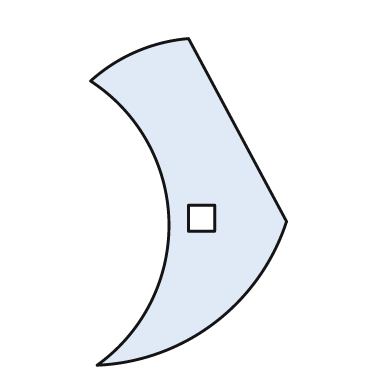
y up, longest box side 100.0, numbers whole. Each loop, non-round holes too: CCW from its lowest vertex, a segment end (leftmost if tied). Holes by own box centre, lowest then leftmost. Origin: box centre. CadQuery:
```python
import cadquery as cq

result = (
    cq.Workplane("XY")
    .moveTo(-28.0, -50.0)
    .threePointArc((8.0, -37.0), (30.0, -6.0))
    .lineTo(0.0, 50.0)
    .threePointArc((-16.0, 46.0), (-30.0, 37.0))
    .threePointArc((-6.0, -6.0), (-28.0, -50.0))
    .close()
    .moveTo(0.0, -9.0)
    .lineTo(8.0, -9.0)
    .lineTo(8.0, -1.0)
    .lineTo(0.0, -1.0)
    .close()
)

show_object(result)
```